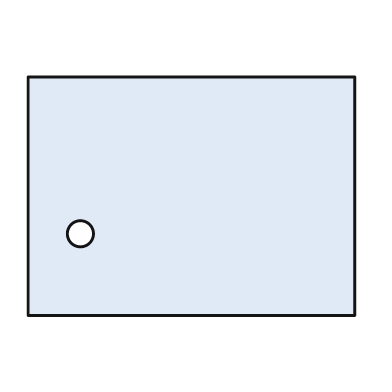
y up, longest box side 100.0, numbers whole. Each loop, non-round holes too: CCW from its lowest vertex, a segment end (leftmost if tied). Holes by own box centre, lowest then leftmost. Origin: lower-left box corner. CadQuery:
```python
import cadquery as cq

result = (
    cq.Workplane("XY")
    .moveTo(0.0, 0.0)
    .lineTo(100.0, 0.0)
    .lineTo(100.0, 73.0)
    .lineTo(0.0, 73.0)
    .close()
    .moveTo(16.0, 25.0)
    .circle(4.0)
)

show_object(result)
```